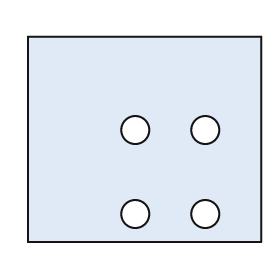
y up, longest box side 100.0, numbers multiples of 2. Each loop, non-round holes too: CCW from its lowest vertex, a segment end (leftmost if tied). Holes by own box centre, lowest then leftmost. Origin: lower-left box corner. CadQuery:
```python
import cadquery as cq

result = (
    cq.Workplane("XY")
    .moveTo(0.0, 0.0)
    .lineTo(100.0, 0.0)
    .lineTo(100.0, 88.0)
    .lineTo(0.0, 88.0)
    .close()
    .moveTo(46.0, 12.0)
    .circle(6.0)
    .moveTo(76.0, 12.0)
    .circle(6.0)
    .moveTo(46.0, 48.0)
    .circle(6.0)
    .moveTo(76.0, 48.0)
    .circle(6.0)
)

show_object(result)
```